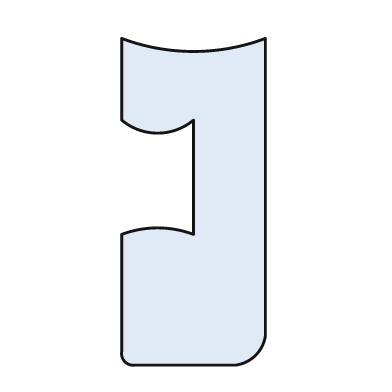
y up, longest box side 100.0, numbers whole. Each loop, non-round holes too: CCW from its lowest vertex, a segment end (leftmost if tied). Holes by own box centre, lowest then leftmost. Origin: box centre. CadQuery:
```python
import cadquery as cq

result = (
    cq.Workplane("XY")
    .moveTo(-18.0, -50.0)
    .lineTo(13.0, -50.0)
    .threePointArc((19.0, -47.0), (22.0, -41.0))
    .lineTo(22.0, 50.0)
    .threePointArc((0.0, 46.0), (-22.0, 50.0))
    .lineTo(-22.0, 25.0)
    .threePointArc((-11.0, 21.0), (0.0, 25.0))
    .lineTo(0.0, -10.0)
    .threePointArc((-11.0, -8.0), (-22.0, -10.0))
    .lineTo(-22.0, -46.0)
    .threePointArc((-21.0, -49.0), (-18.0, -50.0))
    .close()
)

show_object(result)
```